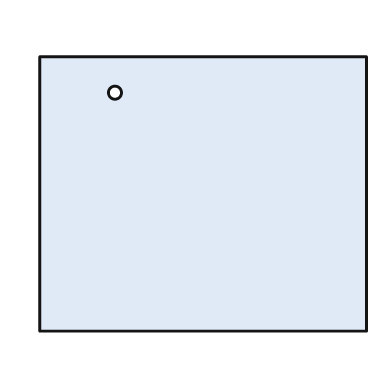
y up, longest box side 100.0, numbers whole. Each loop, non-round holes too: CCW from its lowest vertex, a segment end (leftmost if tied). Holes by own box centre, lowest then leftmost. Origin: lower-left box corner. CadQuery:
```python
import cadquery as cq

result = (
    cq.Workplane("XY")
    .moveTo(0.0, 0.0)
    .lineTo(100.0, 0.0)
    .lineTo(100.0, 84.0)
    .lineTo(0.0, 84.0)
    .close()
    .moveTo(23.0, 73.0)
    .circle(2.0)
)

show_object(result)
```